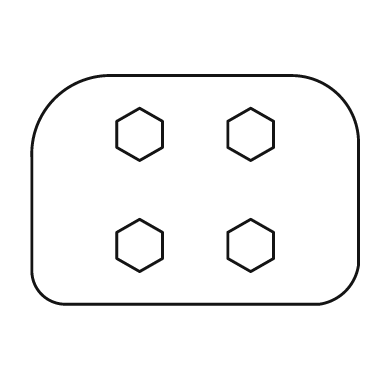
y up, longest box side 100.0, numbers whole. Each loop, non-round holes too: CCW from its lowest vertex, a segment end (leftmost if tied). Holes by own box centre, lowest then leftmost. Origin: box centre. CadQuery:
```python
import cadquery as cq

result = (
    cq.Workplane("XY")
    .moveTo(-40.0, -35.0)
    .lineTo(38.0, -35.0)
    .threePointArc((46.0, -31.0), (50.0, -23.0))
    .lineTo(50.0, 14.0)
    .threePointArc((44.0, 29.0), (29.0, 35.0))
    .lineTo(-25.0, 35.0)
    .threePointArc((-43.0, 28.0), (-50.0, 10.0))
    .lineTo(-50.0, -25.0)
    .threePointArc((-47.0, -32.0), (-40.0, -35.0))
    .close()
    .moveTo(-17.0, -25.0)
    .lineTo(-10.0, -21.0)
    .lineTo(-10.0, -13.0)
    .lineTo(-17.0, -9.0)
    .lineTo(-24.0, -13.0)
    .lineTo(-24.0, -21.0)
    .close()
    .moveTo(17.0, -25.0)
    .lineTo(24.0, -21.0)
    .lineTo(24.0, -13.0)
    .lineTo(17.0, -9.0)
    .lineTo(10.0, -13.0)
    .lineTo(10.0, -21.0)
    .close()
    .moveTo(-17.0, 9.0)
    .lineTo(-10.0, 13.0)
    .lineTo(-10.0, 21.0)
    .lineTo(-17.0, 25.0)
    .lineTo(-24.0, 21.0)
    .lineTo(-24.0, 13.0)
    .close()
    .moveTo(17.0, 9.0)
    .lineTo(24.0, 13.0)
    .lineTo(24.0, 21.0)
    .lineTo(17.0, 25.0)
    .lineTo(10.0, 21.0)
    .lineTo(10.0, 13.0)
    .close()
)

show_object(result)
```